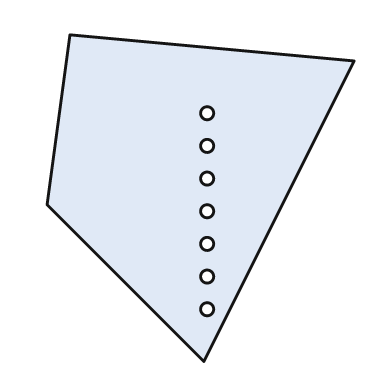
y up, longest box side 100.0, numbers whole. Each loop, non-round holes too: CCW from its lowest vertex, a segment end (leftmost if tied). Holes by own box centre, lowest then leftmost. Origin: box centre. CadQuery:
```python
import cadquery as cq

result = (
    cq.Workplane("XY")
    .moveTo(1.0, -50.0)
    .lineTo(47.0, 42.0)
    .lineTo(-40.0, 50.0)
    .lineTo(-47.0, -2.0)
    .close()
    .moveTo(2.0, -34.0)
    .circle(2.0)
    .moveTo(2.0, -24.0)
    .circle(2.0)
    .moveTo(2.0, -14.0)
    .circle(2.0)
    .moveTo(2.0, -4.0)
    .circle(2.0)
    .moveTo(2.0, 6.0)
    .circle(2.0)
    .moveTo(2.0, 16.0)
    .circle(2.0)
    .moveTo(2.0, 26.0)
    .circle(2.0)
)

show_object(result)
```